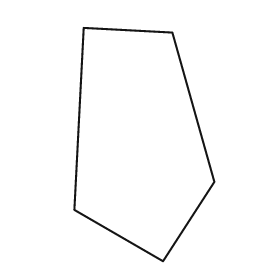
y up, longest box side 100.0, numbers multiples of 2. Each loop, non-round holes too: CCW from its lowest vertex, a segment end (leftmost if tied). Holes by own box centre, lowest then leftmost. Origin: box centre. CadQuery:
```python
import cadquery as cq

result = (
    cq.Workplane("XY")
    .moveTo(8.0, -50.0)
    .lineTo(30.0, -16.0)
    .lineTo(12.0, 48.0)
    .lineTo(-26.0, 50.0)
    .lineTo(-30.0, -28.0)
    .close()
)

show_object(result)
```